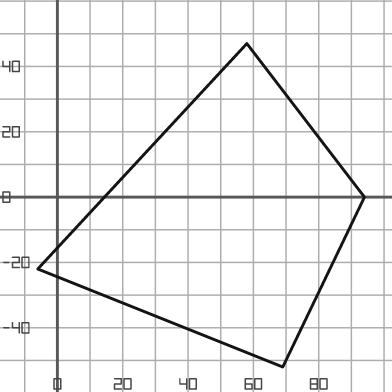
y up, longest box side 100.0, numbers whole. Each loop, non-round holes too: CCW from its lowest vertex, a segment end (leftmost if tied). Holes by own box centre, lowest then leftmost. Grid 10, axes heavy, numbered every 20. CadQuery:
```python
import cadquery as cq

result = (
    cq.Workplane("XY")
    .moveTo(69.0, -52.0)
    .lineTo(94.0, 0.0)
    .lineTo(58.0, 47.0)
    .lineTo(-6.0, -22.0)
    .close()
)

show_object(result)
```